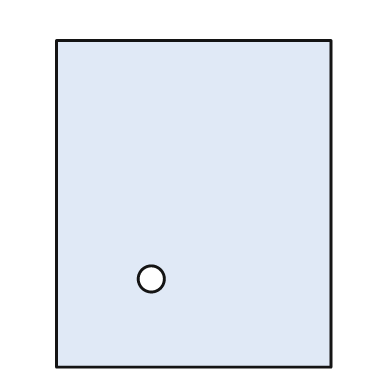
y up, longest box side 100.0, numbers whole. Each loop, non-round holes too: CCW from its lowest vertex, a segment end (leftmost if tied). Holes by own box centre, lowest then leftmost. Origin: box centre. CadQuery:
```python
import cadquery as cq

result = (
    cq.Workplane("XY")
    .moveTo(-42.0, -50.0)
    .lineTo(42.0, -50.0)
    .lineTo(42.0, 50.0)
    .lineTo(-42.0, 50.0)
    .close()
    .moveTo(-13.0, -23.0)
    .circle(4.0)
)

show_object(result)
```